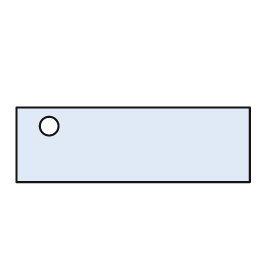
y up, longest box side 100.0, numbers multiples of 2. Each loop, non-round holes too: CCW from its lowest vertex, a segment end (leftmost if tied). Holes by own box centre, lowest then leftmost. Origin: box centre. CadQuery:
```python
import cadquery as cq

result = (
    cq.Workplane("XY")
    .moveTo(-50.0, -16.0)
    .lineTo(50.0, -16.0)
    .lineTo(50.0, 16.0)
    .lineTo(-50.0, 16.0)
    .close()
    .moveTo(-36.0, 8.0)
    .circle(4.0)
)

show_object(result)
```